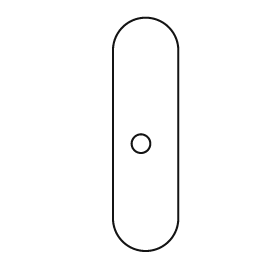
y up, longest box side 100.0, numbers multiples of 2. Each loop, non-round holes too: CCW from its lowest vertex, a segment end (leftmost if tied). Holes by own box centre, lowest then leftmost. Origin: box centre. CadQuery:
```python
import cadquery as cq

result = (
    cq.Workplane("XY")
    .moveTo(-14.0, -36.0)
    .threePointArc((0.0, -50.0), (14.0, -36.0))
    .lineTo(14.0, 36.0)
    .threePointArc((0.0, 50.0), (-14.0, 36.0))
    .close()
    .moveTo(-2.0, -4.0)
    .circle(4.0)
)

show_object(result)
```